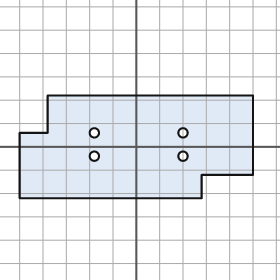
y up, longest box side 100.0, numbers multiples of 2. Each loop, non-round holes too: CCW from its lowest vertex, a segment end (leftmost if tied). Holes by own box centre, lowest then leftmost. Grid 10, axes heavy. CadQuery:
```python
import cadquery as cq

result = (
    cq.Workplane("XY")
    .moveTo(-50.0, -22.0)
    .lineTo(28.0, -22.0)
    .lineTo(28.0, -12.0)
    .lineTo(50.0, -12.0)
    .lineTo(50.0, 22.0)
    .lineTo(-38.0, 22.0)
    .lineTo(-38.0, 6.0)
    .lineTo(-50.0, 6.0)
    .close()
    .moveTo(-18.0, -4.0)
    .circle(2.0)
    .moveTo(20.0, -4.0)
    .circle(2.0)
    .moveTo(-18.0, 6.0)
    .circle(2.0)
    .moveTo(20.0, 6.0)
    .circle(2.0)
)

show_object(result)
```